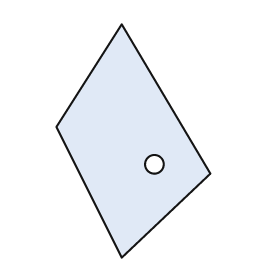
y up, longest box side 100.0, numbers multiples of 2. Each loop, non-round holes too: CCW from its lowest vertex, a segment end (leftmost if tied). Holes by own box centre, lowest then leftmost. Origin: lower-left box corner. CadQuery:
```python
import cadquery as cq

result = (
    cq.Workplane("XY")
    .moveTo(28.0, 0.0)
    .lineTo(66.0, 36.0)
    .lineTo(28.0, 100.0)
    .lineTo(0.0, 56.0)
    .close()
    .moveTo(42.0, 40.0)
    .circle(4.0)
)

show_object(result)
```